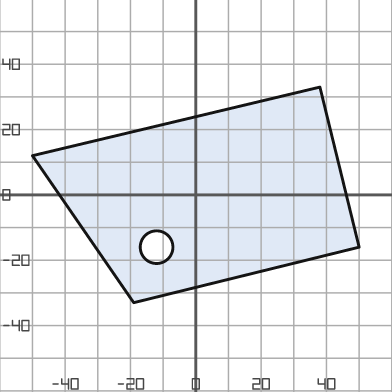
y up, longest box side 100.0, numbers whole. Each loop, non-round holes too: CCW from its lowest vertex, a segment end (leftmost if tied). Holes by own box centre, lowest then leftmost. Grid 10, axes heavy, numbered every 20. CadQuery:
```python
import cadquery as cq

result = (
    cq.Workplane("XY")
    .moveTo(-19.0, -33.0)
    .lineTo(50.0, -16.0)
    .lineTo(38.0, 33.0)
    .lineTo(-50.0, 12.0)
    .close()
    .moveTo(-12.0, -16.0)
    .circle(5.0)
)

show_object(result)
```